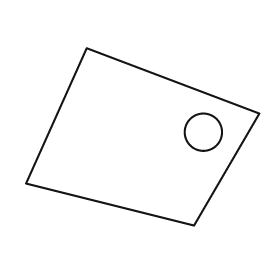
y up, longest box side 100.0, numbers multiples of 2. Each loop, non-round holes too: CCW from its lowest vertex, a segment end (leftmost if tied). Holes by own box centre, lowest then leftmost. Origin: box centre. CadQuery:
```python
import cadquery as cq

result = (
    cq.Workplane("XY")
    .moveTo(22.0, -38.0)
    .lineTo(50.0, 10.0)
    .lineTo(-24.0, 38.0)
    .lineTo(-50.0, -20.0)
    .close()
    .moveTo(26.0, 2.0)
    .circle(8.0)
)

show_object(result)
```